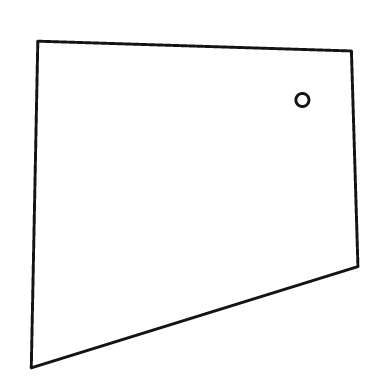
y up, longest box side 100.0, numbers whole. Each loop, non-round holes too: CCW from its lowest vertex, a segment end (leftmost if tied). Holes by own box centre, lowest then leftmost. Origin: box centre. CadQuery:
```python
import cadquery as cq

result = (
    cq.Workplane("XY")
    .moveTo(-50.0, -50.0)
    .lineTo(50.0, -19.0)
    .lineTo(48.0, 47.0)
    .lineTo(-48.0, 50.0)
    .close()
    .moveTo(33.0, 32.0)
    .circle(2.0)
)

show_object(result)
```